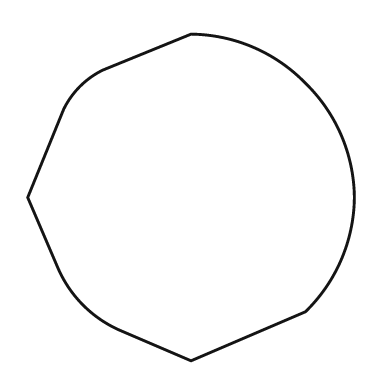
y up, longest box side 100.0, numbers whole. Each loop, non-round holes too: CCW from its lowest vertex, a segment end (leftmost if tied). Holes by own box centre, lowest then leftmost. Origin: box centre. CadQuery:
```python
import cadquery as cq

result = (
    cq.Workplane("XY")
    .moveTo(0.0, -50.0)
    .lineTo(35.0, -35.0)
    .threePointArc((46.0, -19.0), (50.0, 0.0))
    .threePointArc((46.0, 19.0), (35.0, 35.0))
    .threePointArc((19.0, 46.0), (0.0, 50.0))
    .lineTo(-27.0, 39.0)
    .threePointArc((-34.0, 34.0), (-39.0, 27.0))
    .lineTo(-50.0, 0.0)
    .lineTo(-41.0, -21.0)
    .threePointArc((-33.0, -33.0), (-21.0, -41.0))
    .close()
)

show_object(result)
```